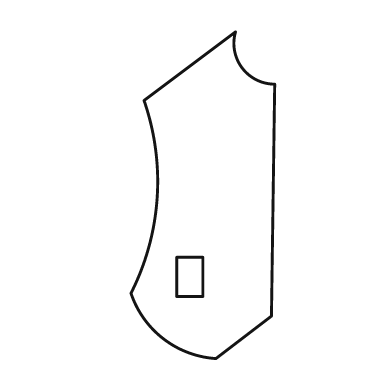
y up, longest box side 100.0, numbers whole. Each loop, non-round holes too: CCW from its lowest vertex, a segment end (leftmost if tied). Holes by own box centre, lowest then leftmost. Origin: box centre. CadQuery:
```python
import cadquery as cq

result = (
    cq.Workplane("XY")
    .moveTo(4.0, -50.0)
    .lineTo(21.0, -37.0)
    .lineTo(22.0, 34.0)
    .threePointArc((12.0, 39.0), (10.0, 50.0))
    .lineTo(-18.0, 29.0)
    .threePointArc((-14.0, -1.0), (-22.0, -30.0))
    .threePointArc((-12.0, -44.0), (4.0, -50.0))
    .close()
    .moveTo(-8.0, -31.0)
    .lineTo(0.0, -31.0)
    .lineTo(0.0, -19.0)
    .lineTo(-8.0, -19.0)
    .close()
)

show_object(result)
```